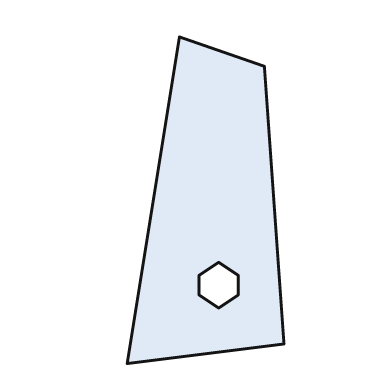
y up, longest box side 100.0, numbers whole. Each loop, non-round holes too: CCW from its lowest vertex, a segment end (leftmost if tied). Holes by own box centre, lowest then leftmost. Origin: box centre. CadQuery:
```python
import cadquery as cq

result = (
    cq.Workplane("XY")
    .moveTo(-24.0, -50.0)
    .lineTo(24.0, -44.0)
    .lineTo(18.0, 41.0)
    .lineTo(-8.0, 50.0)
    .close()
    .moveTo(4.0, -33.0)
    .lineTo(10.0, -29.0)
    .lineTo(10.0, -23.0)
    .lineTo(4.0, -19.0)
    .lineTo(-2.0, -23.0)
    .lineTo(-2.0, -29.0)
    .close()
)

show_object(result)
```